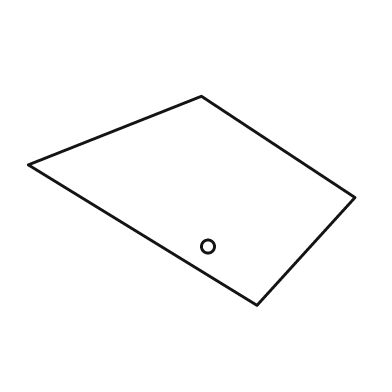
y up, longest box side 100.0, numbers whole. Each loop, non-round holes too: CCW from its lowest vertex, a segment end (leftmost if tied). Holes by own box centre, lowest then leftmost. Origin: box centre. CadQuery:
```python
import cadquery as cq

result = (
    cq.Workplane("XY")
    .moveTo(20.0, -32.0)
    .lineTo(50.0, 1.0)
    .lineTo(3.0, 32.0)
    .lineTo(-50.0, 11.0)
    .close()
    .moveTo(5.0, -14.0)
    .circle(2.0)
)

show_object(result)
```